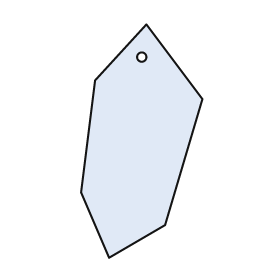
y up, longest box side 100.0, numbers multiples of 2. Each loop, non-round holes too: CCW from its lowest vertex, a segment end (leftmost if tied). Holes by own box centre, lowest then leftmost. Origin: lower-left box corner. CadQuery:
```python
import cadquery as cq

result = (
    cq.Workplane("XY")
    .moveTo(12.0, 0.0)
    .lineTo(36.0, 14.0)
    .lineTo(52.0, 68.0)
    .lineTo(28.0, 100.0)
    .lineTo(6.0, 76.0)
    .lineTo(0.0, 28.0)
    .close()
    .moveTo(26.0, 86.0)
    .circle(2.0)
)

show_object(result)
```